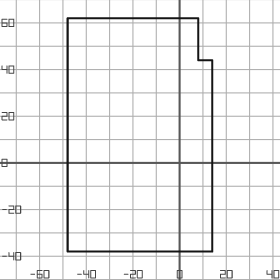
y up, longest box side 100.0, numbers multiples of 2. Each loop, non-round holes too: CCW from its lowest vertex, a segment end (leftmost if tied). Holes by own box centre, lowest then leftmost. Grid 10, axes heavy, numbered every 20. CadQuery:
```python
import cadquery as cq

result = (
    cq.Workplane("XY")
    .moveTo(-48.0, -38.0)
    .lineTo(14.0, -38.0)
    .lineTo(14.0, 44.0)
    .lineTo(8.0, 44.0)
    .lineTo(8.0, 62.0)
    .lineTo(-48.0, 62.0)
    .close()
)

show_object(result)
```